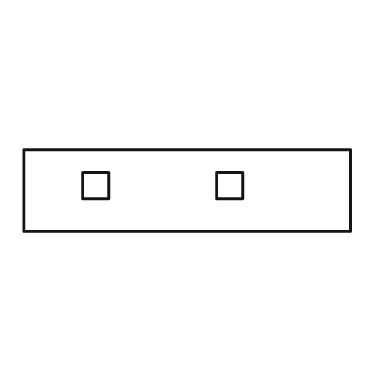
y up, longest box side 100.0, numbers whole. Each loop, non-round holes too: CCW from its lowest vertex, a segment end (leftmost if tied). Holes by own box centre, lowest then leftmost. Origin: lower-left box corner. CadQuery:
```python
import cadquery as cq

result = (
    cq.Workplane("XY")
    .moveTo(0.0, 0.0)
    .lineTo(100.0, 0.0)
    .lineTo(100.0, 25.0)
    .lineTo(0.0, 25.0)
    .close()
    .moveTo(18.0, 10.0)
    .lineTo(26.0, 10.0)
    .lineTo(26.0, 18.0)
    .lineTo(18.0, 18.0)
    .close()
    .moveTo(59.0, 10.0)
    .lineTo(67.0, 10.0)
    .lineTo(67.0, 18.0)
    .lineTo(59.0, 18.0)
    .close()
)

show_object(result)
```